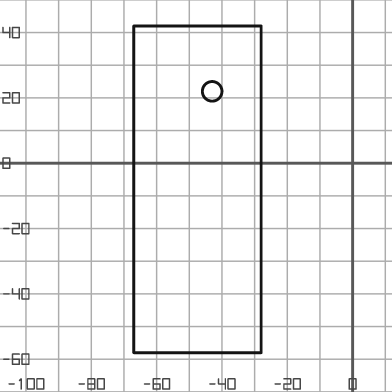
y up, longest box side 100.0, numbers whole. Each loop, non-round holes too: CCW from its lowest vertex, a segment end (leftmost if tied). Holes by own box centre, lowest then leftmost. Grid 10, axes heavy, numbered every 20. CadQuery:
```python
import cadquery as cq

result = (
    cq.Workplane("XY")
    .moveTo(-67.0, -58.0)
    .lineTo(-28.0, -58.0)
    .lineTo(-28.0, 42.0)
    .lineTo(-67.0, 42.0)
    .close()
    .moveTo(-43.0, 22.0)
    .circle(3.0)
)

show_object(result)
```